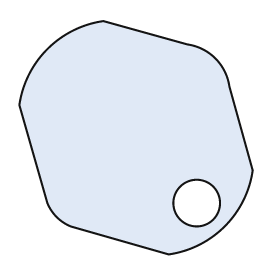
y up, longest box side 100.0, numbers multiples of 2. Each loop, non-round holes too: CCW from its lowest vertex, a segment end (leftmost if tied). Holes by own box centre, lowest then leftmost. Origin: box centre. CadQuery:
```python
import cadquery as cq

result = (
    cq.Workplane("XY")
    .moveTo(14.0, -50.0)
    .threePointArc((38.0, -38.0), (50.0, -14.0))
    .lineTo(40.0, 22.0)
    .threePointArc((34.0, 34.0), (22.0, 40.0))
    .lineTo(-14.0, 50.0)
    .threePointArc((-38.0, 38.0), (-50.0, 14.0))
    .lineTo(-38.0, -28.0)
    .threePointArc((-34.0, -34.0), (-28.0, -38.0))
    .close()
    .moveTo(26.0, -28.0)
    .circle(10.0)
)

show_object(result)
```